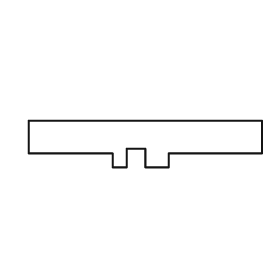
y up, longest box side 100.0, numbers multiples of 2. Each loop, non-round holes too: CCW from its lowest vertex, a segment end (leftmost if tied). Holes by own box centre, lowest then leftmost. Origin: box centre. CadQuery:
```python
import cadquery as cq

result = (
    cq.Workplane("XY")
    .moveTo(-14.0, -10.0)
    .lineTo(-8.0, -10.0)
    .lineTo(-8.0, -2.0)
    .lineTo(0.0, -2.0)
    .lineTo(0.0, -10.0)
    .lineTo(10.0, -10.0)
    .lineTo(10.0, -4.0)
    .lineTo(50.0, -4.0)
    .lineTo(50.0, 10.0)
    .lineTo(-50.0, 10.0)
    .lineTo(-50.0, -4.0)
    .lineTo(-14.0, -4.0)
    .close()
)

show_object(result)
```